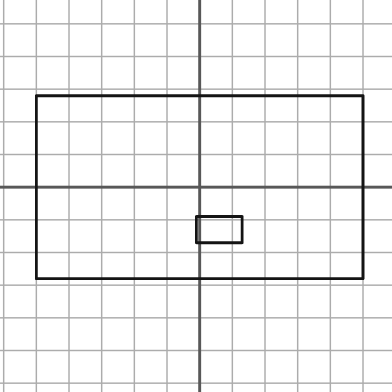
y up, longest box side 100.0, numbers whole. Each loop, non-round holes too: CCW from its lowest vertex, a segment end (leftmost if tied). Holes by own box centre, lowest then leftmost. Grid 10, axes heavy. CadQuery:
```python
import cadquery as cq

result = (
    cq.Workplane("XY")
    .moveTo(-50.0, -28.0)
    .lineTo(50.0, -28.0)
    .lineTo(50.0, 28.0)
    .lineTo(-50.0, 28.0)
    .close()
    .moveTo(-1.0, -17.0)
    .lineTo(13.0, -17.0)
    .lineTo(13.0, -9.0)
    .lineTo(-1.0, -9.0)
    .close()
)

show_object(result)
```